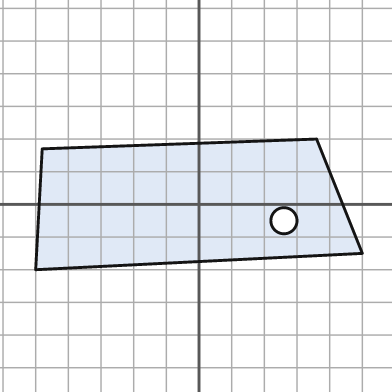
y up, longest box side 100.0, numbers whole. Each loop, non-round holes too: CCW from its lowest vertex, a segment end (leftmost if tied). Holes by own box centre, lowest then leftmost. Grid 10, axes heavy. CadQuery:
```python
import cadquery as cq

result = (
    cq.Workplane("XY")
    .moveTo(-50.0, -20.0)
    .lineTo(50.0, -15.0)
    .lineTo(36.0, 20.0)
    .lineTo(-48.0, 17.0)
    .close()
    .moveTo(26.0, -5.0)
    .circle(4.0)
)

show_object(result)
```